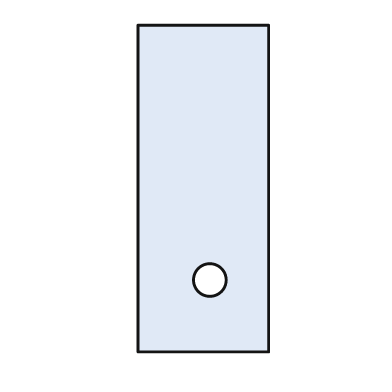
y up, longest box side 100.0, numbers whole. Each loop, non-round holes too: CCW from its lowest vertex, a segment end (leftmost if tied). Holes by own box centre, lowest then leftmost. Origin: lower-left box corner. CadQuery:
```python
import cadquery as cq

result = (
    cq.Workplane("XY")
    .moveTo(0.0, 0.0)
    .lineTo(40.0, 0.0)
    .lineTo(40.0, 100.0)
    .lineTo(0.0, 100.0)
    .close()
    .moveTo(22.0, 22.0)
    .circle(5.0)
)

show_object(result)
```